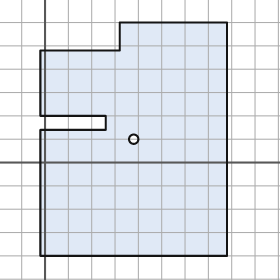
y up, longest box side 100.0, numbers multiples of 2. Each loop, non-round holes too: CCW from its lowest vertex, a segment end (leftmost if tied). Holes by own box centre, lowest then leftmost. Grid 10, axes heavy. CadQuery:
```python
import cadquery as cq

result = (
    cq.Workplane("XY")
    .moveTo(-2.0, -40.0)
    .lineTo(78.0, -40.0)
    .lineTo(78.0, 60.0)
    .lineTo(32.0, 60.0)
    .lineTo(32.0, 48.0)
    .lineTo(-2.0, 48.0)
    .lineTo(-2.0, 20.0)
    .lineTo(26.0, 20.0)
    .lineTo(26.0, 14.0)
    .lineTo(-2.0, 14.0)
    .close()
    .moveTo(38.0, 10.0)
    .circle(2.0)
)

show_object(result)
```